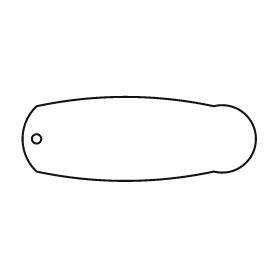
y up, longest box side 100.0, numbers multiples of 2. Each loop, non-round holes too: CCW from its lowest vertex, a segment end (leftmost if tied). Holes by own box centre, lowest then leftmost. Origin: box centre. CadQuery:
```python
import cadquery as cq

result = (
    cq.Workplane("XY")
    .moveTo(-44.0, -14.0)
    .threePointArc((-6.0, -18.0), (32.0, -14.0))
    .threePointArc((50.0, 0.0), (32.0, 14.0))
    .threePointArc((-6.0, 18.0), (-44.0, 14.0))
    .threePointArc((-50.0, 0.0), (-44.0, -14.0))
    .close()
    .moveTo(-44.0, 0.0)
    .circle(2.0)
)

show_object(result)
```